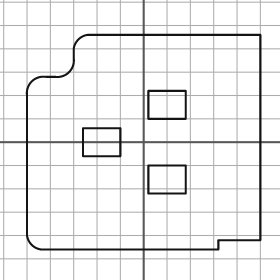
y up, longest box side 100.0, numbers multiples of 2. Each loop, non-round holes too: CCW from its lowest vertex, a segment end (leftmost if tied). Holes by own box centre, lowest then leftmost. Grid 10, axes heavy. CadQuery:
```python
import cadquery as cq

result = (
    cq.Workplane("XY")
    .moveTo(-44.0, -46.0)
    .lineTo(32.0, -46.0)
    .lineTo(32.0, -42.0)
    .lineTo(50.0, -42.0)
    .lineTo(50.0, 46.0)
    .lineTo(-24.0, 46.0)
    .threePointArc((-28.0, 44.0), (-30.0, 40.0))
    .lineTo(-30.0, 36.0)
    .threePointArc((-32.0, 30.0), (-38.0, 28.0))
    .lineTo(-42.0, 28.0)
    .threePointArc((-48.0, 26.0), (-50.0, 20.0))
    .lineTo(-50.0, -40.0)
    .threePointArc((-48.0, -44.0), (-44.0, -46.0))
    .close()
    .moveTo(2.0, -22.0)
    .lineTo(18.0, -22.0)
    .lineTo(18.0, -10.0)
    .lineTo(2.0, -10.0)
    .close()
    .moveTo(-26.0, -6.0)
    .lineTo(-10.0, -6.0)
    .lineTo(-10.0, 6.0)
    .lineTo(-26.0, 6.0)
    .close()
    .moveTo(2.0, 10.0)
    .lineTo(18.0, 10.0)
    .lineTo(18.0, 22.0)
    .lineTo(2.0, 22.0)
    .close()
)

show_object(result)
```